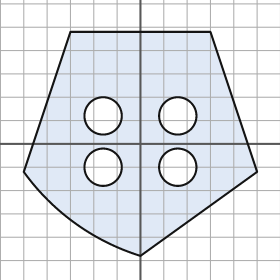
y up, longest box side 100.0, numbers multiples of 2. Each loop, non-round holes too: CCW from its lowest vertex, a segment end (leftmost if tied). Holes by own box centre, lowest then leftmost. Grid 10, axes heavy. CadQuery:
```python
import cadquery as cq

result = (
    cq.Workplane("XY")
    .moveTo(0.0, -48.0)
    .lineTo(50.0, -12.0)
    .lineTo(30.0, 48.0)
    .lineTo(-30.0, 48.0)
    .lineTo(-50.0, -12.0)
    .threePointArc((-28.0, -34.0), (0.0, -48.0))
    .close()
    .moveTo(-16.0, -10.0)
    .circle(8.0)
    .moveTo(16.0, -10.0)
    .circle(8.0)
    .moveTo(-16.0, 12.0)
    .circle(8.0)
    .moveTo(16.0, 12.0)
    .circle(8.0)
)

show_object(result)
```